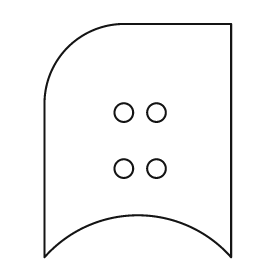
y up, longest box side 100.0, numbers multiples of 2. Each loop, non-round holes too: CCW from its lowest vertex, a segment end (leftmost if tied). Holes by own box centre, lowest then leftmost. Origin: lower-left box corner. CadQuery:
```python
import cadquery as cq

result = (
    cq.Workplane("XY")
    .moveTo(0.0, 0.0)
    .threePointArc((40.0, 18.0), (80.0, 0.0))
    .lineTo(80.0, 100.0)
    .lineTo(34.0, 100.0)
    .threePointArc((10.0, 90.0), (0.0, 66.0))
    .close()
    .moveTo(34.0, 38.0)
    .circle(4.0)
    .moveTo(48.0, 38.0)
    .circle(4.0)
    .moveTo(34.0, 62.0)
    .circle(4.0)
    .moveTo(48.0, 62.0)
    .circle(4.0)
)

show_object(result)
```